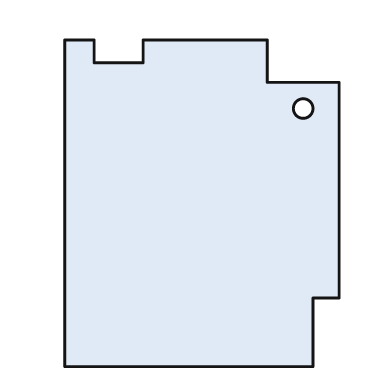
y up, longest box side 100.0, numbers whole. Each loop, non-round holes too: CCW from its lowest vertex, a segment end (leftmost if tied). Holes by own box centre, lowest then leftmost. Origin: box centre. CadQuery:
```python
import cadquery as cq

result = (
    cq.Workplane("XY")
    .moveTo(-42.0, -50.0)
    .lineTo(34.0, -50.0)
    .lineTo(34.0, -29.0)
    .lineTo(42.0, -29.0)
    .lineTo(42.0, 37.0)
    .lineTo(20.0, 37.0)
    .lineTo(20.0, 50.0)
    .lineTo(-18.0, 50.0)
    .lineTo(-18.0, 43.0)
    .lineTo(-33.0, 43.0)
    .lineTo(-33.0, 50.0)
    .lineTo(-42.0, 50.0)
    .close()
    .moveTo(31.0, 29.0)
    .circle(3.0)
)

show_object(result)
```